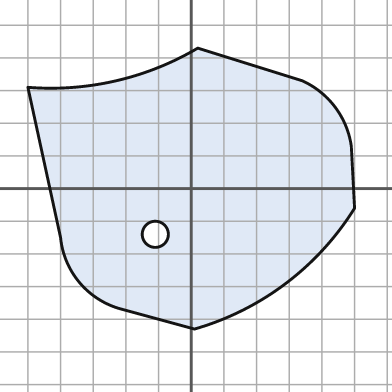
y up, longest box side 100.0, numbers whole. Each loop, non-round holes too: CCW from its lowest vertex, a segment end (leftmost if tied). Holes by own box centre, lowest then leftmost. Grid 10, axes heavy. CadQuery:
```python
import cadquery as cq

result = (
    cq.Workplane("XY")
    .moveTo(1.0, -43.0)
    .threePointArc((29.0, -29.0), (50.0, -6.0))
    .lineTo(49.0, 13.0)
    .threePointArc((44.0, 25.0), (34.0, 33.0))
    .lineTo(2.0, 43.0)
    .threePointArc((-23.0, 33.0), (-50.0, 31.0))
    .lineTo(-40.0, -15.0)
    .threePointArc((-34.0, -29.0), (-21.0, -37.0))
    .close()
    .moveTo(-11.0, -14.0)
    .circle(4.0)
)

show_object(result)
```